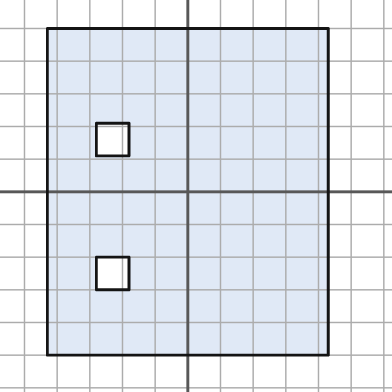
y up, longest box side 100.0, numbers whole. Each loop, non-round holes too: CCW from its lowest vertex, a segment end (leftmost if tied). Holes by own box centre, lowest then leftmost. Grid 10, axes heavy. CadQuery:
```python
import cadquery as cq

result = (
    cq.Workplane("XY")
    .moveTo(-43.0, -50.0)
    .lineTo(43.0, -50.0)
    .lineTo(43.0, 50.0)
    .lineTo(-43.0, 50.0)
    .close()
    .moveTo(-28.0, -30.0)
    .lineTo(-18.0, -30.0)
    .lineTo(-18.0, -20.0)
    .lineTo(-28.0, -20.0)
    .close()
    .moveTo(-28.0, 11.0)
    .lineTo(-18.0, 11.0)
    .lineTo(-18.0, 21.0)
    .lineTo(-28.0, 21.0)
    .close()
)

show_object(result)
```